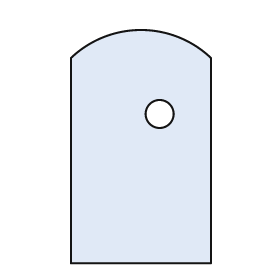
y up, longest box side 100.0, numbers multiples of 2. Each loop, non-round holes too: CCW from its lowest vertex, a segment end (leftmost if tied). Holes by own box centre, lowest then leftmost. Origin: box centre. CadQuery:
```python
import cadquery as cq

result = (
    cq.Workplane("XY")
    .moveTo(-30.0, -50.0)
    .lineTo(30.0, -50.0)
    .lineTo(30.0, 38.0)
    .threePointArc((0.0, 50.0), (-30.0, 38.0))
    .close()
    .moveTo(8.0, 14.0)
    .circle(6.0)
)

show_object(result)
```